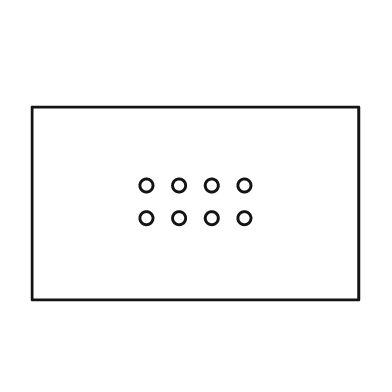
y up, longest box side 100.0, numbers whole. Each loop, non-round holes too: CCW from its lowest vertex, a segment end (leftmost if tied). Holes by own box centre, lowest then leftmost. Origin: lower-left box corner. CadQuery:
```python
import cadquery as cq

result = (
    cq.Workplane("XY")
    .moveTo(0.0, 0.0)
    .lineTo(100.0, 0.0)
    .lineTo(100.0, 59.0)
    .lineTo(0.0, 59.0)
    .close()
    .moveTo(35.0, 25.0)
    .circle(2.0)
    .moveTo(45.0, 25.0)
    .circle(2.0)
    .moveTo(55.0, 25.0)
    .circle(2.0)
    .moveTo(65.0, 25.0)
    .circle(2.0)
    .moveTo(35.0, 35.0)
    .circle(2.0)
    .moveTo(45.0, 35.0)
    .circle(2.0)
    .moveTo(55.0, 35.0)
    .circle(2.0)
    .moveTo(65.0, 35.0)
    .circle(2.0)
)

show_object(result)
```